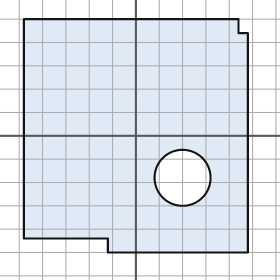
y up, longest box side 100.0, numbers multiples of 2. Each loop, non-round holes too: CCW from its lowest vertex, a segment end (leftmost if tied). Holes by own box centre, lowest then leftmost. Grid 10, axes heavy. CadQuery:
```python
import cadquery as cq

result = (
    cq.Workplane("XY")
    .moveTo(-12.0, -50.0)
    .lineTo(48.0, -50.0)
    .lineTo(48.0, 44.0)
    .lineTo(44.0, 44.0)
    .lineTo(44.0, 50.0)
    .lineTo(-48.0, 50.0)
    .lineTo(-48.0, -44.0)
    .lineTo(-12.0, -44.0)
    .close()
    .moveTo(20.0, -18.0)
    .circle(12.0)
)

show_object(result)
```